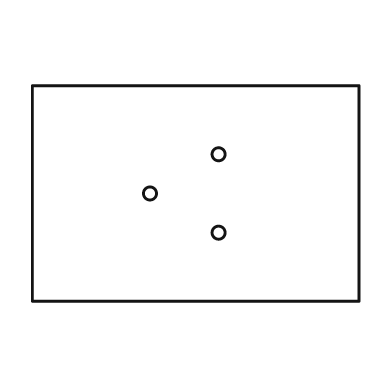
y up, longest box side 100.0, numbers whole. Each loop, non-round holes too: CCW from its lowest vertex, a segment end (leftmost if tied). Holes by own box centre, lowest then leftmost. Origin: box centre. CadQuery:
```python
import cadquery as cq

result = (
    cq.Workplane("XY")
    .moveTo(-50.0, -33.0)
    .lineTo(50.0, -33.0)
    .lineTo(50.0, 33.0)
    .lineTo(-50.0, 33.0)
    .close()
    .moveTo(7.0, -12.0)
    .circle(2.0)
    .moveTo(-14.0, 0.0)
    .circle(2.0)
    .moveTo(7.0, 12.0)
    .circle(2.0)
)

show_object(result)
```